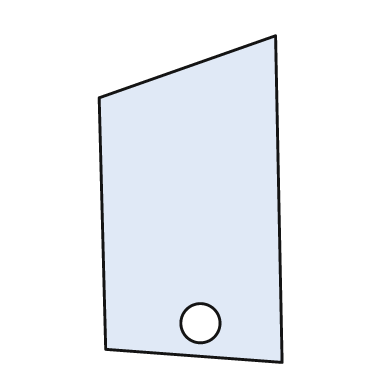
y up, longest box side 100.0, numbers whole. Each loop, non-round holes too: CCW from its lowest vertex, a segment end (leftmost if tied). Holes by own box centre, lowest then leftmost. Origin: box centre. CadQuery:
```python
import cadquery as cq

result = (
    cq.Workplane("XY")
    .moveTo(28.0, -50.0)
    .lineTo(26.0, 50.0)
    .lineTo(-28.0, 31.0)
    .lineTo(-26.0, -46.0)
    .close()
    .moveTo(3.0, -38.0)
    .circle(6.0)
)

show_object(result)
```